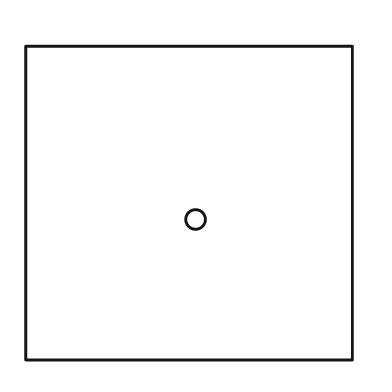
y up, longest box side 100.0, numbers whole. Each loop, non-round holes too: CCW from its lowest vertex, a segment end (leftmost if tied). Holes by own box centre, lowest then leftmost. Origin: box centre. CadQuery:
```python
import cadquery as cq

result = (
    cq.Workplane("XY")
    .moveTo(-50.0, -48.0)
    .lineTo(50.0, -48.0)
    .lineTo(50.0, 48.0)
    .lineTo(-50.0, 48.0)
    .close()
    .moveTo(2.0, -5.0)
    .circle(3.0)
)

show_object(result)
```